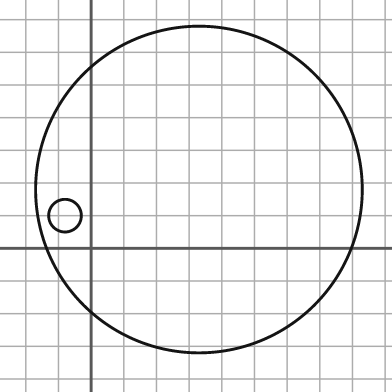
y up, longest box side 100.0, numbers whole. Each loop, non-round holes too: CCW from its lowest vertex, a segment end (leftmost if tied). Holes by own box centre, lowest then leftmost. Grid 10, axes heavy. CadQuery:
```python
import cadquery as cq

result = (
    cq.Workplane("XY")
    .moveTo(33.0, 18.0)
    .circle(50.0)
    .moveTo(-8.0, 10.0)
    .circle(5.0)
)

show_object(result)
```